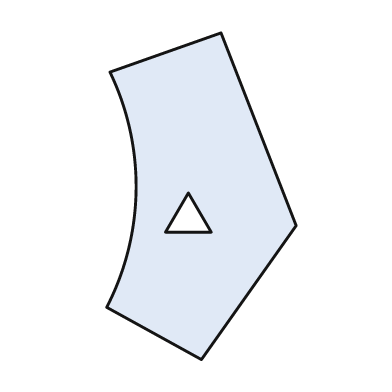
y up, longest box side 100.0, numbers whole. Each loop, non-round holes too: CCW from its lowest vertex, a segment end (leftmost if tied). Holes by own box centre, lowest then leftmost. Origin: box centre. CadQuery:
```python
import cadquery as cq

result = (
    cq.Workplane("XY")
    .moveTo(0.0, -50.0)
    .lineTo(29.0, -9.0)
    .lineTo(6.0, 50.0)
    .lineTo(-28.0, 38.0)
    .threePointArc((-20.0, 2.0), (-29.0, -34.0))
    .close()
    .moveTo(-11.0, -11.0)
    .lineTo(3.0, -11.0)
    .lineTo(-4.0, 1.0)
    .close()
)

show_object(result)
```